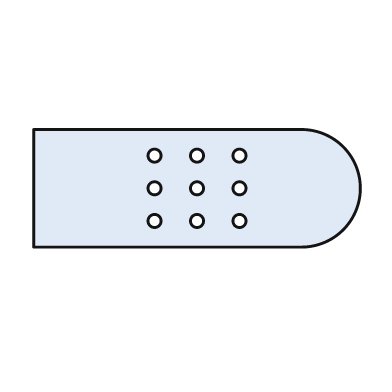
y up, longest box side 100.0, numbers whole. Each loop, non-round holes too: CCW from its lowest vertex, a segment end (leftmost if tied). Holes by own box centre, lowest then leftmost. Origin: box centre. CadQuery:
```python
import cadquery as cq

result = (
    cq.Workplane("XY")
    .moveTo(-50.0, -18.0)
    .lineTo(32.0, -18.0)
    .threePointArc((50.0, 0.0), (32.0, 18.0))
    .lineTo(-50.0, 18.0)
    .close()
    .moveTo(-13.0, -10.0)
    .circle(2.0)
    .moveTo(0.0, -10.0)
    .circle(2.0)
    .moveTo(13.0, -10.0)
    .circle(2.0)
    .moveTo(-13.0, 0.0)
    .circle(2.0)
    .moveTo(0.0, 0.0)
    .circle(2.0)
    .moveTo(13.0, 0.0)
    .circle(2.0)
    .moveTo(-13.0, 10.0)
    .circle(2.0)
    .moveTo(0.0, 10.0)
    .circle(2.0)
    .moveTo(13.0, 10.0)
    .circle(2.0)
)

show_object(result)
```